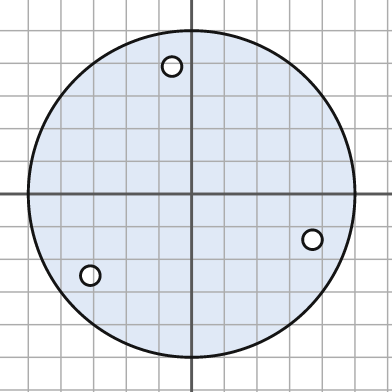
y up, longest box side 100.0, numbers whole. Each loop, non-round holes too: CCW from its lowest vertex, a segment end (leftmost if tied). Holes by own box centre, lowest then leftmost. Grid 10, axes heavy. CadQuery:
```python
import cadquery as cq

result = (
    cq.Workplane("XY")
    .moveTo(0.0, 0.0)
    .circle(50.0)
    .moveTo(-31.0, -25.0)
    .circle(3.0)
    .moveTo(37.0, -14.0)
    .circle(3.0)
    .moveTo(-6.0, 39.0)
    .circle(3.0)
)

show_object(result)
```